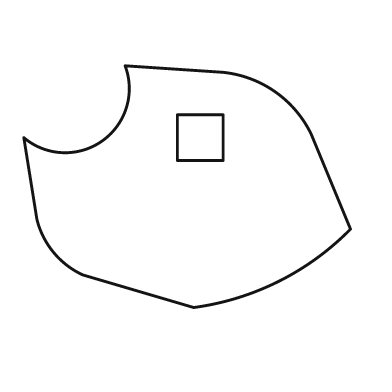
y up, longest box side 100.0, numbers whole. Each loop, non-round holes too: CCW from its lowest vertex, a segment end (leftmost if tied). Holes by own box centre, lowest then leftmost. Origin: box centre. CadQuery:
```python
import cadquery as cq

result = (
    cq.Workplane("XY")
    .moveTo(2.0, -37.0)
    .threePointArc((28.0, -29.0), (50.0, -13.0))
    .lineTo(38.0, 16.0)
    .threePointArc((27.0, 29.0), (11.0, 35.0))
    .lineTo(-19.0, 37.0)
    .threePointArc((-26.0, 14.0), (-50.0, 15.0))
    .lineTo(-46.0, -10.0)
    .threePointArc((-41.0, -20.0), (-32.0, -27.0))
    .close()
    .moveTo(-3.0, 8.0)
    .lineTo(11.0, 8.0)
    .lineTo(11.0, 22.0)
    .lineTo(-3.0, 22.0)
    .close()
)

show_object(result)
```